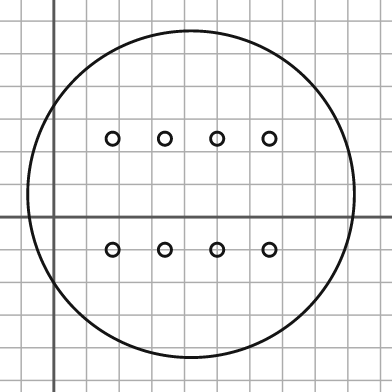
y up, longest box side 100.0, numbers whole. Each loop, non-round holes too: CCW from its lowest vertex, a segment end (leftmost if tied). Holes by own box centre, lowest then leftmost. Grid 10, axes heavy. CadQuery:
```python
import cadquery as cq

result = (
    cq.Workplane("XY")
    .moveTo(42.0, 7.0)
    .circle(50.0)
    .moveTo(18.0, -10.0)
    .circle(2.0)
    .moveTo(34.0, -10.0)
    .circle(2.0)
    .moveTo(50.0, -10.0)
    .circle(2.0)
    .moveTo(66.0, -10.0)
    .circle(2.0)
    .moveTo(18.0, 24.0)
    .circle(2.0)
    .moveTo(34.0, 24.0)
    .circle(2.0)
    .moveTo(50.0, 24.0)
    .circle(2.0)
    .moveTo(66.0, 24.0)
    .circle(2.0)
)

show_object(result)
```